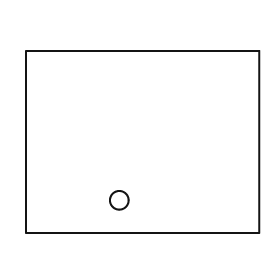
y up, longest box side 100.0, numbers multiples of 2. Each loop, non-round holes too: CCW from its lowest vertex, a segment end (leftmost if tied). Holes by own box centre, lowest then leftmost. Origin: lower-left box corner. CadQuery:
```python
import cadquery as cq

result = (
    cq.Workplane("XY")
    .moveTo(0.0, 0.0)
    .lineTo(100.0, 0.0)
    .lineTo(100.0, 78.0)
    .lineTo(0.0, 78.0)
    .close()
    .moveTo(40.0, 14.0)
    .circle(4.0)
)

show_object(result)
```